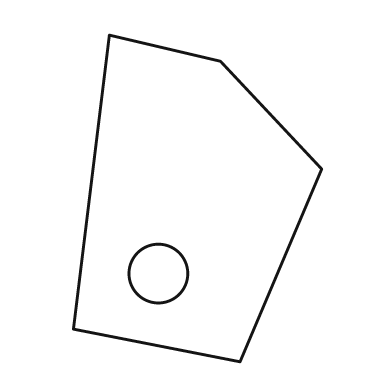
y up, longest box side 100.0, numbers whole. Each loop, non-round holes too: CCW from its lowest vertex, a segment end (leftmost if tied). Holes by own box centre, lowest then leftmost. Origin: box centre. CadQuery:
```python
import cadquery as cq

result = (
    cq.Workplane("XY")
    .moveTo(13.0, -50.0)
    .lineTo(38.0, 9.0)
    .lineTo(7.0, 42.0)
    .lineTo(-27.0, 50.0)
    .lineTo(-38.0, -40.0)
    .close()
    .moveTo(-12.0, -23.0)
    .circle(9.0)
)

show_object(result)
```